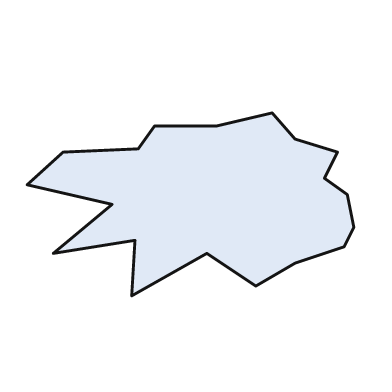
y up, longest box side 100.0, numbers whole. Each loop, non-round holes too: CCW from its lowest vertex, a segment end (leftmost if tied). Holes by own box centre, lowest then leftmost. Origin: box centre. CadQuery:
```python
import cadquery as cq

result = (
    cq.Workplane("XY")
    .moveTo(-18.0, -28.0)
    .lineTo(5.0, -15.0)
    .lineTo(20.0, -25.0)
    .lineTo(32.0, -18.0)
    .lineTo(47.0, -13.0)
    .lineTo(50.0, -7.0)
    .lineTo(48.0, 3.0)
    .lineTo(41.0, 8.0)
    .lineTo(45.0, 16.0)
    .lineTo(32.0, 20.0)
    .lineTo(25.0, 28.0)
    .lineTo(8.0, 24.0)
    .lineTo(-11.0, 24.0)
    .lineTo(-16.0, 17.0)
    .lineTo(-39.0, 16.0)
    .lineTo(-50.0, 6.0)
    .lineTo(-24.0, 0.0)
    .lineTo(-42.0, -15.0)
    .lineTo(-17.0, -11.0)
    .close()
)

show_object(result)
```